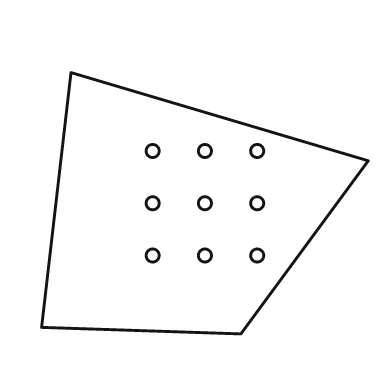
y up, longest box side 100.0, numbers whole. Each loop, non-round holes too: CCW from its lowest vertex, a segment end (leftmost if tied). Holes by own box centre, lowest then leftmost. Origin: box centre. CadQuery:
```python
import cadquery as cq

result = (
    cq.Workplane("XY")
    .moveTo(11.0, -40.0)
    .lineTo(50.0, 13.0)
    .lineTo(-41.0, 40.0)
    .lineTo(-50.0, -38.0)
    .close()
    .moveTo(-16.0, -16.0)
    .circle(2.0)
    .moveTo(0.0, -16.0)
    .circle(2.0)
    .moveTo(16.0, -16.0)
    .circle(2.0)
    .moveTo(-16.0, 0.0)
    .circle(2.0)
    .moveTo(0.0, 0.0)
    .circle(2.0)
    .moveTo(16.0, 0.0)
    .circle(2.0)
    .moveTo(-16.0, 16.0)
    .circle(2.0)
    .moveTo(0.0, 16.0)
    .circle(2.0)
    .moveTo(16.0, 16.0)
    .circle(2.0)
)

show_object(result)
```